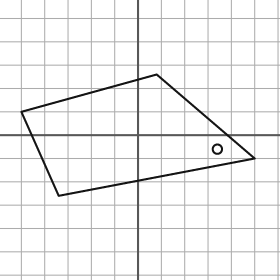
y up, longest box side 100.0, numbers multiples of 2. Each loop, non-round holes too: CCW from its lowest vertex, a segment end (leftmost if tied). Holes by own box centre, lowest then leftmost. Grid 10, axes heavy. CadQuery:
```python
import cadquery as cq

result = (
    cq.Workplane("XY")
    .moveTo(-34.0, -26.0)
    .lineTo(50.0, -10.0)
    .lineTo(8.0, 26.0)
    .lineTo(-50.0, 10.0)
    .close()
    .moveTo(34.0, -6.0)
    .circle(2.0)
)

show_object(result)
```